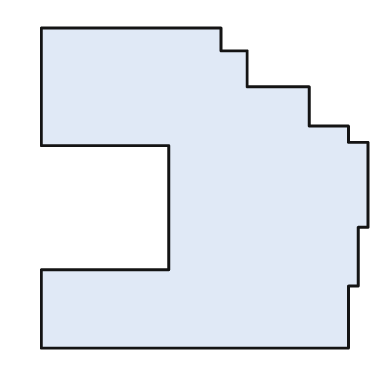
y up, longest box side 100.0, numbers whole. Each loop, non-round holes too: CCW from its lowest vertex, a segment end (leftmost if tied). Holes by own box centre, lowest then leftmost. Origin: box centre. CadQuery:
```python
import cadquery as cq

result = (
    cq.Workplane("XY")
    .moveTo(-50.0, -49.0)
    .lineTo(44.0, -49.0)
    .lineTo(44.0, -30.0)
    .lineTo(47.0, -30.0)
    .lineTo(47.0, -12.0)
    .lineTo(50.0, -12.0)
    .lineTo(50.0, 14.0)
    .lineTo(44.0, 14.0)
    .lineTo(44.0, 19.0)
    .lineTo(32.0, 19.0)
    .lineTo(32.0, 31.0)
    .lineTo(13.0, 31.0)
    .lineTo(13.0, 42.0)
    .lineTo(5.0, 42.0)
    .lineTo(5.0, 49.0)
    .lineTo(-50.0, 49.0)
    .lineTo(-50.0, 13.0)
    .lineTo(-11.0, 13.0)
    .lineTo(-11.0, -25.0)
    .lineTo(-50.0, -25.0)
    .close()
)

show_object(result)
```